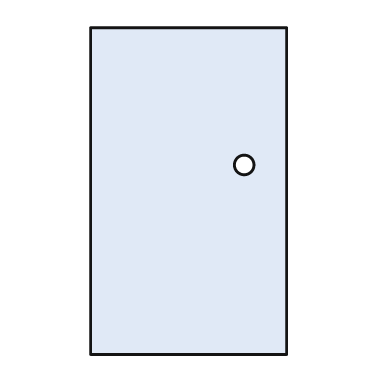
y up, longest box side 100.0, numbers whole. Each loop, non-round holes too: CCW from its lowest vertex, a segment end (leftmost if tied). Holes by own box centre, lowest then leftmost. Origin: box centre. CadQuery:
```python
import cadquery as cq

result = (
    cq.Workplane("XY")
    .moveTo(-30.0, -50.0)
    .lineTo(30.0, -50.0)
    .lineTo(30.0, 50.0)
    .lineTo(-30.0, 50.0)
    .close()
    .moveTo(17.0, 8.0)
    .circle(3.0)
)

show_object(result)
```